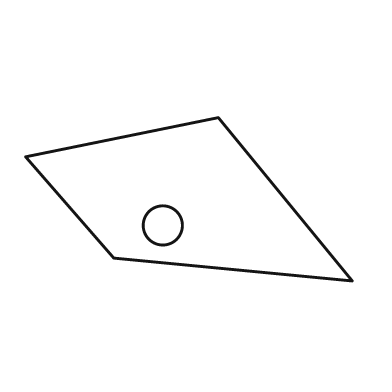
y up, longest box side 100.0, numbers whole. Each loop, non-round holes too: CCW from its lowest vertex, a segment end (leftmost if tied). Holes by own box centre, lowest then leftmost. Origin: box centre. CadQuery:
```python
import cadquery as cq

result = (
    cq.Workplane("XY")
    .moveTo(50.0, -25.0)
    .lineTo(9.0, 25.0)
    .lineTo(-50.0, 13.0)
    .lineTo(-23.0, -18.0)
    .close()
    .moveTo(-8.0, -8.0)
    .circle(6.0)
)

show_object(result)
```